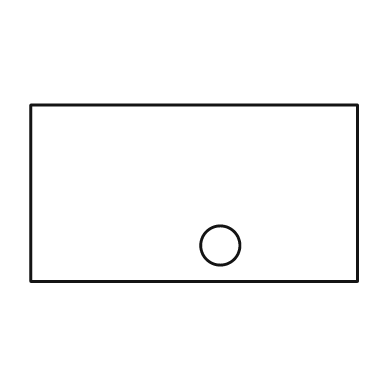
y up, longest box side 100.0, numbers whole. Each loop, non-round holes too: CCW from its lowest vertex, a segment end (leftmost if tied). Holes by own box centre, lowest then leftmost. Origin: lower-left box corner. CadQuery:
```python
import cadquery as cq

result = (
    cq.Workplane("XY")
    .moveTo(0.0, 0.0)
    .lineTo(100.0, 0.0)
    .lineTo(100.0, 54.0)
    .lineTo(0.0, 54.0)
    .close()
    .moveTo(58.0, 11.0)
    .circle(6.0)
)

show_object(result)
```